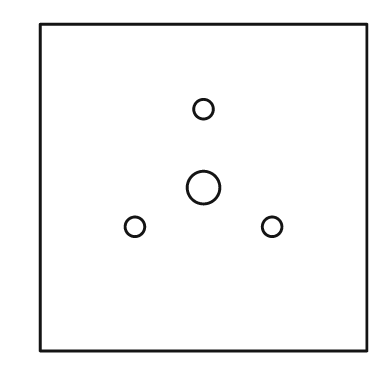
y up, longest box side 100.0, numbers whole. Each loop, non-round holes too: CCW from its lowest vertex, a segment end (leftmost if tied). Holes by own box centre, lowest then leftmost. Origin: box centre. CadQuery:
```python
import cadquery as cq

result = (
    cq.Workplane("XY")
    .moveTo(-50.0, -50.0)
    .lineTo(50.0, -50.0)
    .lineTo(50.0, 50.0)
    .lineTo(-50.0, 50.0)
    .close()
    .moveTo(-21.0, -12.0)
    .circle(3.0)
    .moveTo(21.0, -12.0)
    .circle(3.0)
    .moveTo(0.0, 0.0)
    .circle(5.0)
    .moveTo(0.0, 24.0)
    .circle(3.0)
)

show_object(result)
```